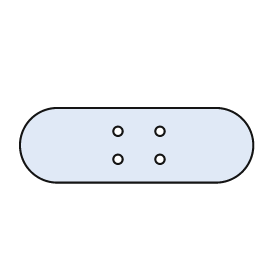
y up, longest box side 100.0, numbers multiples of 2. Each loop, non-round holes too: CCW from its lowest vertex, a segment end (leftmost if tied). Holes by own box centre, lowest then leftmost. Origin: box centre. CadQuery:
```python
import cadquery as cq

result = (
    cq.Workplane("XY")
    .moveTo(-34.0, -16.0)
    .lineTo(34.0, -16.0)
    .threePointArc((50.0, 0.0), (34.0, 16.0))
    .lineTo(-34.0, 16.0)
    .threePointArc((-50.0, 0.0), (-34.0, -16.0))
    .close()
    .moveTo(-8.0, -6.0)
    .circle(2.0)
    .moveTo(10.0, -6.0)
    .circle(2.0)
    .moveTo(-8.0, 6.0)
    .circle(2.0)
    .moveTo(10.0, 6.0)
    .circle(2.0)
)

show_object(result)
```